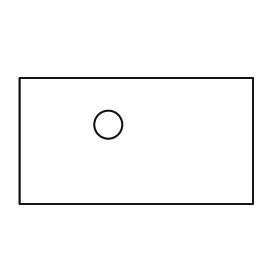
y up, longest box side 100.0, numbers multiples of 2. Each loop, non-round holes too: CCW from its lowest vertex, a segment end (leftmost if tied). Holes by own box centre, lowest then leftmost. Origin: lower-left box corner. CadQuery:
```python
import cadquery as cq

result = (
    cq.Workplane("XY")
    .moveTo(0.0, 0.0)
    .lineTo(100.0, 0.0)
    .lineTo(100.0, 54.0)
    .lineTo(0.0, 54.0)
    .close()
    .moveTo(38.0, 34.0)
    .circle(6.0)
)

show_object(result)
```